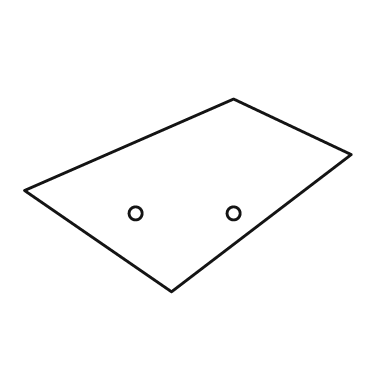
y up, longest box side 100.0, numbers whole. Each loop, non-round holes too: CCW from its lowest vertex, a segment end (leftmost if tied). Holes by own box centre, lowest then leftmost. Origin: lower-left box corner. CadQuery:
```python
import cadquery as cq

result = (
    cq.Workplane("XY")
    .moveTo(45.0, 0.0)
    .lineTo(100.0, 42.0)
    .lineTo(64.0, 59.0)
    .lineTo(0.0, 31.0)
    .close()
    .moveTo(34.0, 24.0)
    .circle(2.0)
    .moveTo(64.0, 24.0)
    .circle(2.0)
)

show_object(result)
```